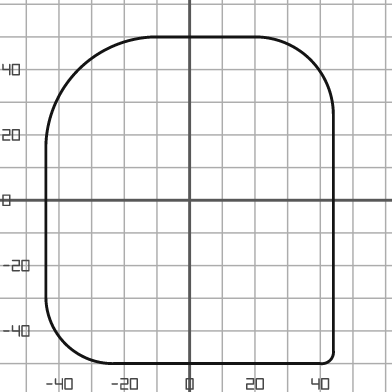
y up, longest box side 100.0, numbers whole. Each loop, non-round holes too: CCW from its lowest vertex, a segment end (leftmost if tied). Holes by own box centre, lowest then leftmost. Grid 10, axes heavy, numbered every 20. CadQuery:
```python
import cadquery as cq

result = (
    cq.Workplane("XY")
    .moveTo(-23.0, -50.0)
    .lineTo(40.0, -50.0)
    .threePointArc((43.0, -49.0), (44.0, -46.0))
    .lineTo(44.0, 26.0)
    .threePointArc((37.0, 43.0), (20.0, 50.0))
    .lineTo(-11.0, 50.0)
    .threePointArc((-34.0, 40.0), (-44.0, 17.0))
    .lineTo(-44.0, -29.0)
    .threePointArc((-38.0, -44.0), (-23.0, -50.0))
    .close()
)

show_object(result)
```